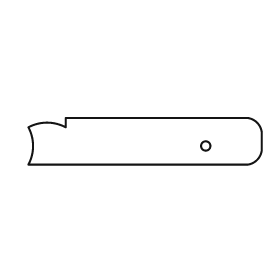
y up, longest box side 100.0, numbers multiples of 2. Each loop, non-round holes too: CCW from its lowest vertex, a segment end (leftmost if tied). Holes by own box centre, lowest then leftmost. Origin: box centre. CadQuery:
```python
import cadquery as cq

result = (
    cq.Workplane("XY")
    .moveTo(-50.0, -10.0)
    .lineTo(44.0, -10.0)
    .threePointArc((48.0, -8.0), (50.0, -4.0))
    .lineTo(50.0, 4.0)
    .threePointArc((48.0, 8.0), (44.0, 10.0))
    .lineTo(-34.0, 10.0)
    .lineTo(-34.0, 6.0)
    .threePointArc((-42.0, 8.0), (-50.0, 6.0))
    .threePointArc((-48.0, -2.0), (-50.0, -10.0))
    .close()
    .moveTo(26.0, -2.0)
    .circle(2.0)
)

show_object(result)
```